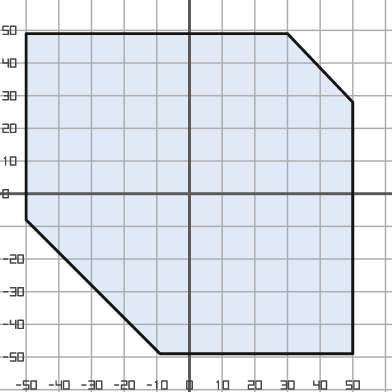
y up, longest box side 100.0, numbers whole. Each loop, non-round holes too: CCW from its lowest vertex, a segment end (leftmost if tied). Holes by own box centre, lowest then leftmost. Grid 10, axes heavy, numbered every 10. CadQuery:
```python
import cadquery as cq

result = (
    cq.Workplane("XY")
    .moveTo(-9.0, -49.0)
    .lineTo(50.0, -49.0)
    .lineTo(50.0, 28.0)
    .lineTo(30.0, 49.0)
    .lineTo(-50.0, 49.0)
    .lineTo(-50.0, -8.0)
    .close()
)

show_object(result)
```